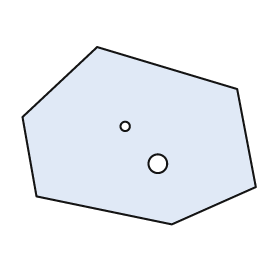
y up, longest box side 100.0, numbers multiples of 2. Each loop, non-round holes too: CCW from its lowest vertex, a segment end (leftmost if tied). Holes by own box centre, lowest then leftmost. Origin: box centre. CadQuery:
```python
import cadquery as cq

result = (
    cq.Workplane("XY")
    .moveTo(14.0, -38.0)
    .lineTo(50.0, -22.0)
    .lineTo(42.0, 20.0)
    .lineTo(-18.0, 38.0)
    .lineTo(-50.0, 8.0)
    .lineTo(-44.0, -26.0)
    .close()
    .moveTo(8.0, -12.0)
    .circle(4.0)
    .moveTo(-6.0, 4.0)
    .circle(2.0)
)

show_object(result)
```